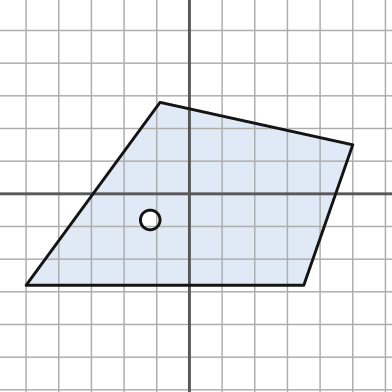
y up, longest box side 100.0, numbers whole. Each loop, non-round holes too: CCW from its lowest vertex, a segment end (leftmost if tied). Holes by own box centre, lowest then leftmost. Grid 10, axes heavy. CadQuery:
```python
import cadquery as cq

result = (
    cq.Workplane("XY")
    .moveTo(-50.0, -28.0)
    .lineTo(35.0, -28.0)
    .lineTo(50.0, 15.0)
    .lineTo(-9.0, 28.0)
    .close()
    .moveTo(-12.0, -8.0)
    .circle(3.0)
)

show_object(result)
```